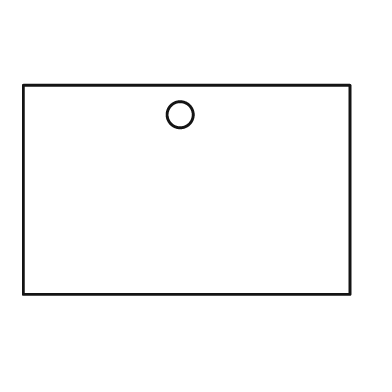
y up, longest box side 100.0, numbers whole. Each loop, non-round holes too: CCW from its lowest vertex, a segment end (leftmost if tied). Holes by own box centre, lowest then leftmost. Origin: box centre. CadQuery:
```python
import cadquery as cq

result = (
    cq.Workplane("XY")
    .moveTo(-50.0, -32.0)
    .lineTo(50.0, -32.0)
    .lineTo(50.0, 32.0)
    .lineTo(-50.0, 32.0)
    .close()
    .moveTo(-2.0, 23.0)
    .circle(4.0)
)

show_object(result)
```